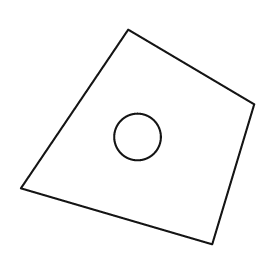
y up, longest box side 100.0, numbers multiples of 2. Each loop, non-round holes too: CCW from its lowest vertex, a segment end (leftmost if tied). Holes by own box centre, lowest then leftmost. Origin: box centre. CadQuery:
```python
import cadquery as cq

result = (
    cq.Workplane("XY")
    .moveTo(32.0, -46.0)
    .lineTo(50.0, 14.0)
    .lineTo(-4.0, 46.0)
    .lineTo(-50.0, -22.0)
    .close()
    .moveTo(0.0, 0.0)
    .circle(10.0)
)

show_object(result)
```